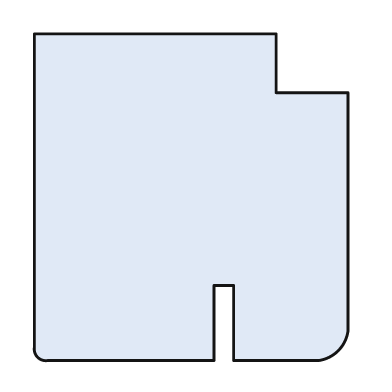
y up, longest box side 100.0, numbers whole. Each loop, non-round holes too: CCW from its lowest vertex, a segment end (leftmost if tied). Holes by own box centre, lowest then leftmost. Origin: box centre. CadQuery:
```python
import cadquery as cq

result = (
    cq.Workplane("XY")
    .moveTo(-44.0, -50.0)
    .lineTo(7.0, -50.0)
    .lineTo(7.0, -27.0)
    .lineTo(13.0, -27.0)
    .lineTo(13.0, -50.0)
    .lineTo(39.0, -50.0)
    .threePointArc((45.0, -47.0), (48.0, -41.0))
    .lineTo(48.0, 32.0)
    .lineTo(26.0, 32.0)
    .lineTo(26.0, 50.0)
    .lineTo(-48.0, 50.0)
    .lineTo(-48.0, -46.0)
    .threePointArc((-47.0, -49.0), (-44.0, -50.0))
    .close()
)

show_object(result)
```